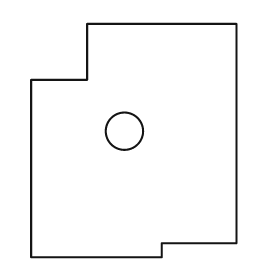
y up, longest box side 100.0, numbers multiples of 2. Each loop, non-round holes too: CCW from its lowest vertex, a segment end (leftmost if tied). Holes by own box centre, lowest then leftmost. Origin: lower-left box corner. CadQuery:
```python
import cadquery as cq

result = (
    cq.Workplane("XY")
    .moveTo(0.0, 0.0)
    .lineTo(56.0, 0.0)
    .lineTo(56.0, 6.0)
    .lineTo(88.0, 6.0)
    .lineTo(88.0, 100.0)
    .lineTo(24.0, 100.0)
    .lineTo(24.0, 76.0)
    .lineTo(0.0, 76.0)
    .close()
    .moveTo(40.0, 54.0)
    .circle(8.0)
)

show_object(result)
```